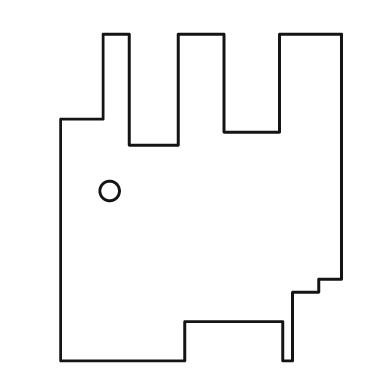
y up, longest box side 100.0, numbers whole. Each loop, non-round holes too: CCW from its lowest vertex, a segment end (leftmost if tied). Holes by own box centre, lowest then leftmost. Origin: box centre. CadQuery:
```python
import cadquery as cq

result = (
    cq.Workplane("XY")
    .moveTo(-43.0, -50.0)
    .lineTo(-5.0, -50.0)
    .lineTo(-5.0, -38.0)
    .lineTo(25.0, -38.0)
    .lineTo(25.0, -50.0)
    .lineTo(28.0, -50.0)
    .lineTo(28.0, -29.0)
    .lineTo(36.0, -29.0)
    .lineTo(36.0, -25.0)
    .lineTo(43.0, -25.0)
    .lineTo(43.0, 50.0)
    .lineTo(24.0, 50.0)
    .lineTo(24.0, 20.0)
    .lineTo(7.0, 20.0)
    .lineTo(7.0, 50.0)
    .lineTo(-7.0, 50.0)
    .lineTo(-7.0, 16.0)
    .lineTo(-22.0, 16.0)
    .lineTo(-22.0, 50.0)
    .lineTo(-30.0, 50.0)
    .lineTo(-30.0, 24.0)
    .lineTo(-43.0, 24.0)
    .close()
    .moveTo(-28.0, 2.0)
    .circle(3.0)
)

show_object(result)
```